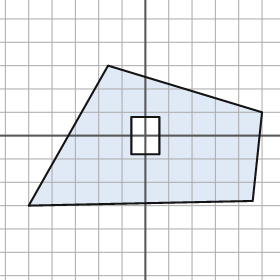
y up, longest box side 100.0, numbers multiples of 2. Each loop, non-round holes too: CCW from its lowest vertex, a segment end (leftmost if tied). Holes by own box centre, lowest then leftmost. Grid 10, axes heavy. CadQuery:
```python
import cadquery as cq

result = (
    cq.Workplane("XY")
    .moveTo(-50.0, -30.0)
    .lineTo(46.0, -28.0)
    .lineTo(50.0, 10.0)
    .lineTo(-16.0, 30.0)
    .close()
    .moveTo(-6.0, -8.0)
    .lineTo(6.0, -8.0)
    .lineTo(6.0, 8.0)
    .lineTo(-6.0, 8.0)
    .close()
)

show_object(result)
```